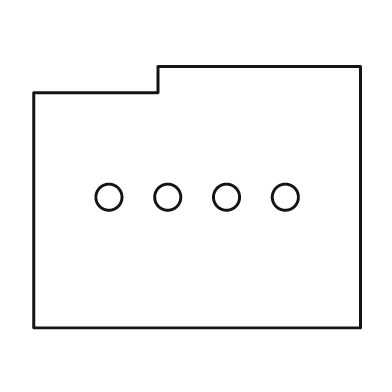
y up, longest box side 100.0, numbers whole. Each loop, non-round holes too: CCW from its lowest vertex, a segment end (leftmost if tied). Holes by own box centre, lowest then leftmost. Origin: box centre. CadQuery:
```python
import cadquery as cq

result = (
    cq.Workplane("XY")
    .moveTo(-50.0, -40.0)
    .lineTo(50.0, -40.0)
    .lineTo(50.0, 40.0)
    .lineTo(-12.0, 40.0)
    .lineTo(-12.0, 32.0)
    .lineTo(-50.0, 32.0)
    .close()
    .moveTo(-27.0, 0.0)
    .circle(4.0)
    .moveTo(-9.0, 0.0)
    .circle(4.0)
    .moveTo(9.0, 0.0)
    .circle(4.0)
    .moveTo(27.0, 0.0)
    .circle(4.0)
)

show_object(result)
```